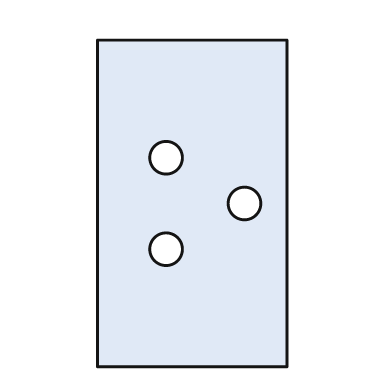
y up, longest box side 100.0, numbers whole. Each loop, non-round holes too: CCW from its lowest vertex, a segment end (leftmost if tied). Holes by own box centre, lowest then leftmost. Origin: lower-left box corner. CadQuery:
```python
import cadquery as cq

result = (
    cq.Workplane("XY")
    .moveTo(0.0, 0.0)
    .lineTo(58.0, 0.0)
    .lineTo(58.0, 100.0)
    .lineTo(0.0, 100.0)
    .close()
    .moveTo(21.0, 36.0)
    .circle(5.0)
    .moveTo(45.0, 50.0)
    .circle(5.0)
    .moveTo(21.0, 64.0)
    .circle(5.0)
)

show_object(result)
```